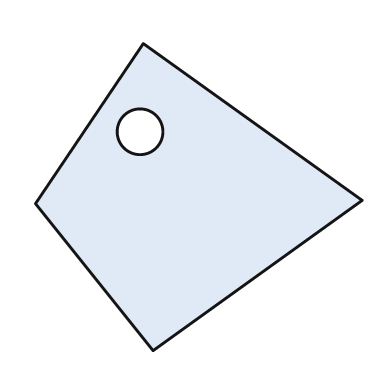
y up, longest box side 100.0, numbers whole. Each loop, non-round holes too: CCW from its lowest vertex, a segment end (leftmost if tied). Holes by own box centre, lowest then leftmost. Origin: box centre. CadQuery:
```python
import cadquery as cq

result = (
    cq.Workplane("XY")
    .moveTo(-14.0, -47.0)
    .lineTo(50.0, -1.0)
    .lineTo(-17.0, 47.0)
    .lineTo(-50.0, -2.0)
    .close()
    .moveTo(-18.0, 20.0)
    .circle(7.0)
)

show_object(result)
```